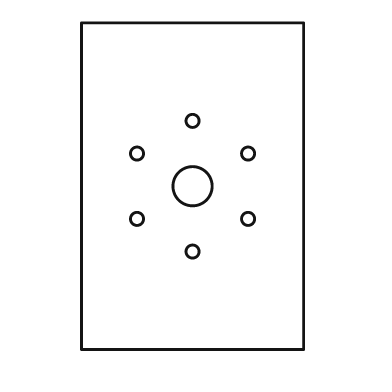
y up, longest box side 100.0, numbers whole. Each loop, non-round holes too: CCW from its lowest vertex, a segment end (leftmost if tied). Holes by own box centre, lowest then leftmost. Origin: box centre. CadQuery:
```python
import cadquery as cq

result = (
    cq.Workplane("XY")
    .moveTo(-34.0, -50.0)
    .lineTo(34.0, -50.0)
    .lineTo(34.0, 50.0)
    .lineTo(-34.0, 50.0)
    .close()
    .moveTo(0.0, -20.0)
    .circle(2.0)
    .moveTo(-17.0, -10.0)
    .circle(2.0)
    .moveTo(17.0, -10.0)
    .circle(2.0)
    .moveTo(0.0, 0.0)
    .circle(6.0)
    .moveTo(-17.0, 10.0)
    .circle(2.0)
    .moveTo(17.0, 10.0)
    .circle(2.0)
    .moveTo(0.0, 20.0)
    .circle(2.0)
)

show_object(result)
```